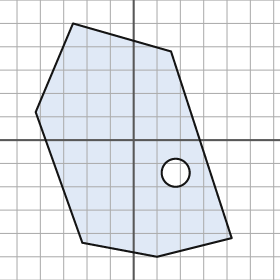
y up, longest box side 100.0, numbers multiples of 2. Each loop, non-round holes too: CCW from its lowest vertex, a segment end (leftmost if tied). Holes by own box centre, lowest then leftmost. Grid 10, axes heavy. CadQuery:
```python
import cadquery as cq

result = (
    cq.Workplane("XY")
    .moveTo(10.0, -50.0)
    .lineTo(42.0, -42.0)
    .lineTo(16.0, 38.0)
    .lineTo(-26.0, 50.0)
    .lineTo(-42.0, 12.0)
    .lineTo(-22.0, -44.0)
    .close()
    .moveTo(18.0, -14.0)
    .circle(6.0)
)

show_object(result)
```